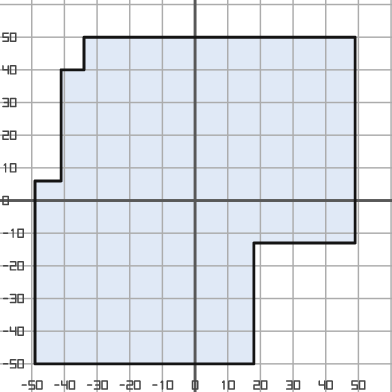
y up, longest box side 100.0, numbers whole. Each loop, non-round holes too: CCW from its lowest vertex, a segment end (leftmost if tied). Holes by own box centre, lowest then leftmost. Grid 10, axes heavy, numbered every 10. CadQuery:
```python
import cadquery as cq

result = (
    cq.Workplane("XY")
    .moveTo(-49.0, -50.0)
    .lineTo(18.0, -50.0)
    .lineTo(18.0, -13.0)
    .lineTo(49.0, -13.0)
    .lineTo(49.0, 50.0)
    .lineTo(-34.0, 50.0)
    .lineTo(-34.0, 40.0)
    .lineTo(-41.0, 40.0)
    .lineTo(-41.0, 6.0)
    .lineTo(-49.0, 6.0)
    .close()
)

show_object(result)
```